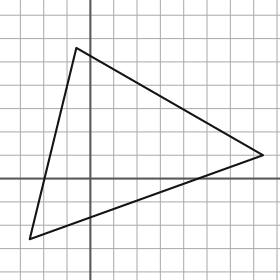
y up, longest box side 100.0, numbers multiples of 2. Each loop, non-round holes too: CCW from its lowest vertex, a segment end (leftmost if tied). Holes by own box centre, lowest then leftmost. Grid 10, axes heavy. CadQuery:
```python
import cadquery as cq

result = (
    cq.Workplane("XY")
    .moveTo(-26.0, -26.0)
    .lineTo(74.0, 10.0)
    .lineTo(-6.0, 56.0)
    .close()
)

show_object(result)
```